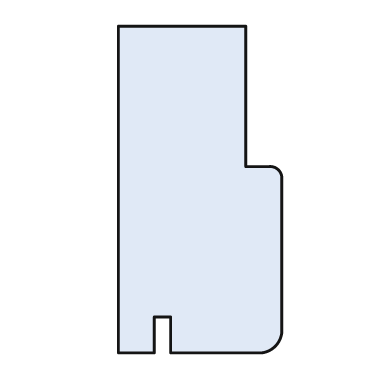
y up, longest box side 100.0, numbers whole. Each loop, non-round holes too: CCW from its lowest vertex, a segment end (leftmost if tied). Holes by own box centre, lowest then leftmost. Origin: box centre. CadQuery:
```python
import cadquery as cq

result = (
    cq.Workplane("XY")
    .moveTo(-25.0, -50.0)
    .lineTo(-14.0, -50.0)
    .lineTo(-14.0, -39.0)
    .lineTo(-9.0, -39.0)
    .lineTo(-9.0, -50.0)
    .lineTo(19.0, -50.0)
    .threePointArc((23.0, -48.0), (25.0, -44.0))
    .lineTo(25.0, 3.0)
    .threePointArc((24.0, 6.0), (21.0, 7.0))
    .lineTo(14.0, 7.0)
    .lineTo(14.0, 50.0)
    .lineTo(-25.0, 50.0)
    .close()
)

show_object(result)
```